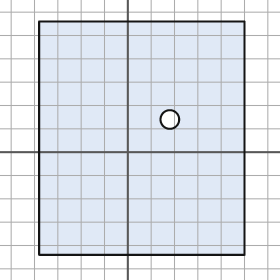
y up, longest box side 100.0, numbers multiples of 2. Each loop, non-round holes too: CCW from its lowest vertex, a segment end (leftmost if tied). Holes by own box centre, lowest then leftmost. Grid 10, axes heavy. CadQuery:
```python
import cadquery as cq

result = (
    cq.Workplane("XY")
    .moveTo(-38.0, -44.0)
    .lineTo(50.0, -44.0)
    .lineTo(50.0, 56.0)
    .lineTo(-38.0, 56.0)
    .close()
    .moveTo(18.0, 14.0)
    .circle(4.0)
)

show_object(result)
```